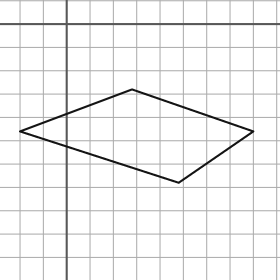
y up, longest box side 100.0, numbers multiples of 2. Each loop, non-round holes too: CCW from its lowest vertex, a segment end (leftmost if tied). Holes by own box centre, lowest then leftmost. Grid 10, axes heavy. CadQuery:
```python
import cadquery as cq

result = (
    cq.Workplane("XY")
    .moveTo(48.0, -68.0)
    .lineTo(80.0, -46.0)
    .lineTo(28.0, -28.0)
    .lineTo(-20.0, -46.0)
    .close()
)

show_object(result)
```